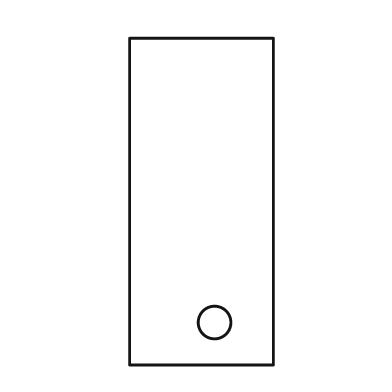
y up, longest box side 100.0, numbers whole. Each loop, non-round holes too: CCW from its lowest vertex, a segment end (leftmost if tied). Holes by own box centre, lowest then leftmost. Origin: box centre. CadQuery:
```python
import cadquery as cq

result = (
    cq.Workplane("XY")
    .moveTo(-22.0, -50.0)
    .lineTo(22.0, -50.0)
    .lineTo(22.0, 50.0)
    .lineTo(-22.0, 50.0)
    .close()
    .moveTo(4.0, -37.0)
    .circle(5.0)
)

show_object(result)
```